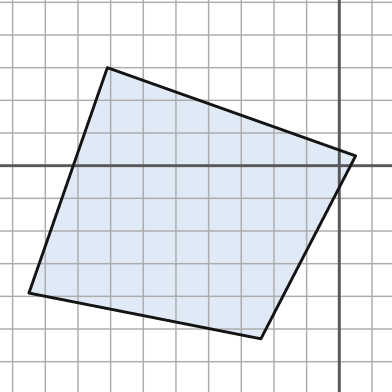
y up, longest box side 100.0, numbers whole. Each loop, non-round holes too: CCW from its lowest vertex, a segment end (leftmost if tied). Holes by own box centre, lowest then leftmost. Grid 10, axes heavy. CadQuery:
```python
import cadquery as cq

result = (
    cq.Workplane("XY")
    .moveTo(-24.0, -53.0)
    .lineTo(5.0, 3.0)
    .lineTo(-71.0, 30.0)
    .lineTo(-95.0, -39.0)
    .close()
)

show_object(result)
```